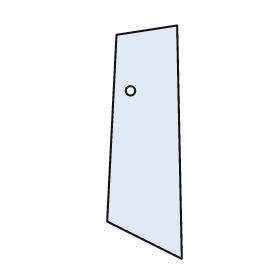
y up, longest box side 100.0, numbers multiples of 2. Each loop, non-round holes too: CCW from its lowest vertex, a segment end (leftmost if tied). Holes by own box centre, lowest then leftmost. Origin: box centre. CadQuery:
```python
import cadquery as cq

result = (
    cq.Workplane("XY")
    .moveTo(16.0, -50.0)
    .lineTo(14.0, 50.0)
    .lineTo(-12.0, 46.0)
    .lineTo(-16.0, -34.0)
    .close()
    .moveTo(-6.0, 22.0)
    .circle(2.0)
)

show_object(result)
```